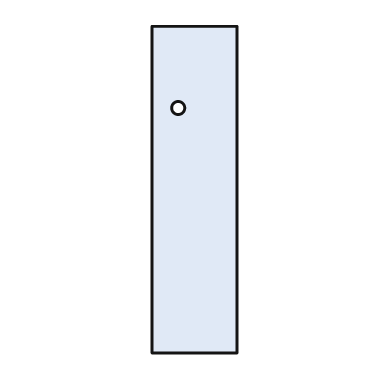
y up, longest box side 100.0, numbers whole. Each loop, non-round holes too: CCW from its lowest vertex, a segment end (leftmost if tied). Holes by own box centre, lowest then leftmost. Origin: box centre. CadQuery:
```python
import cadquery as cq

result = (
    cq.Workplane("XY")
    .moveTo(-13.0, -50.0)
    .lineTo(13.0, -50.0)
    .lineTo(13.0, 50.0)
    .lineTo(-13.0, 50.0)
    .close()
    .moveTo(-5.0, 25.0)
    .circle(2.0)
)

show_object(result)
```